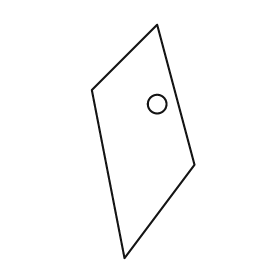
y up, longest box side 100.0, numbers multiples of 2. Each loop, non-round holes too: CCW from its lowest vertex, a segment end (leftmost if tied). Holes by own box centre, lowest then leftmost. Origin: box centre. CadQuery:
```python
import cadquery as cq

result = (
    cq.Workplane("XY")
    .moveTo(-8.0, -50.0)
    .lineTo(22.0, -10.0)
    .lineTo(6.0, 50.0)
    .lineTo(-22.0, 22.0)
    .close()
    .moveTo(6.0, 16.0)
    .circle(4.0)
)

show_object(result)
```